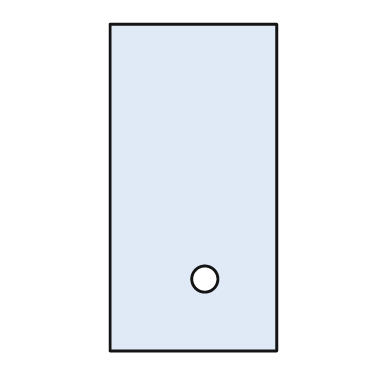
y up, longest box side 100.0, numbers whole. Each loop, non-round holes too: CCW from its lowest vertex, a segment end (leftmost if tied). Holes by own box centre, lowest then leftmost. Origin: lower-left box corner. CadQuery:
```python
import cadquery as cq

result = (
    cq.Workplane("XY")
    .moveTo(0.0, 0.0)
    .lineTo(51.0, 0.0)
    .lineTo(51.0, 100.0)
    .lineTo(0.0, 100.0)
    .close()
    .moveTo(29.0, 22.0)
    .circle(4.0)
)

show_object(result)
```